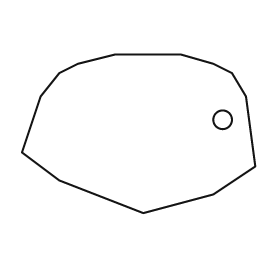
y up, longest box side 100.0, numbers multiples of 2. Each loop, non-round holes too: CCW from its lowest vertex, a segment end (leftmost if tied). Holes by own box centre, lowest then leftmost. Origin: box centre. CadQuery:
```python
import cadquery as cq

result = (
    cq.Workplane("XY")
    .moveTo(2.0, -34.0)
    .lineTo(32.0, -26.0)
    .lineTo(50.0, -14.0)
    .lineTo(46.0, 16.0)
    .lineTo(40.0, 26.0)
    .lineTo(32.0, 30.0)
    .lineTo(18.0, 34.0)
    .lineTo(-10.0, 34.0)
    .lineTo(-26.0, 30.0)
    .lineTo(-34.0, 26.0)
    .lineTo(-42.0, 16.0)
    .lineTo(-50.0, -8.0)
    .lineTo(-34.0, -20.0)
    .close()
    .moveTo(36.0, 6.0)
    .circle(4.0)
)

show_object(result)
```